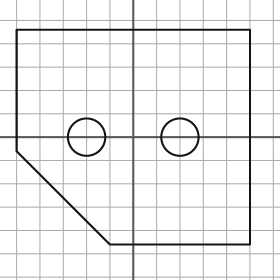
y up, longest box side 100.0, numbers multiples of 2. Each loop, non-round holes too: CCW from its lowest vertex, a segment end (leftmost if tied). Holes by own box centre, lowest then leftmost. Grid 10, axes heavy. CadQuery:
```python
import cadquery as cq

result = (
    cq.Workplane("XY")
    .moveTo(-10.0, -46.0)
    .lineTo(50.0, -46.0)
    .lineTo(50.0, 46.0)
    .lineTo(-50.0, 46.0)
    .lineTo(-50.0, -6.0)
    .close()
    .moveTo(-20.0, 0.0)
    .circle(8.0)
    .moveTo(20.0, 0.0)
    .circle(8.0)
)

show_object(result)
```